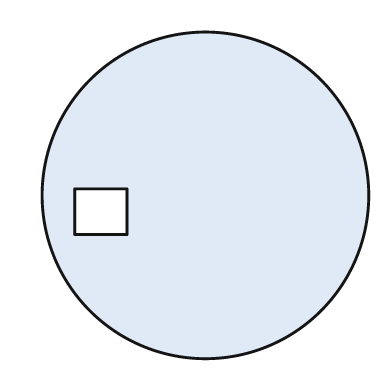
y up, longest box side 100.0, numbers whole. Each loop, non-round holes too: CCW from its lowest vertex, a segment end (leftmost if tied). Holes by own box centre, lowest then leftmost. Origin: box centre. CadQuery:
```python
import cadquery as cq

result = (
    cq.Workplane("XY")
    .moveTo(0.0, 0.0)
    .circle(50.0)
    .moveTo(-40.0, -12.0)
    .lineTo(-24.0, -12.0)
    .lineTo(-24.0, 2.0)
    .lineTo(-40.0, 2.0)
    .close()
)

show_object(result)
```